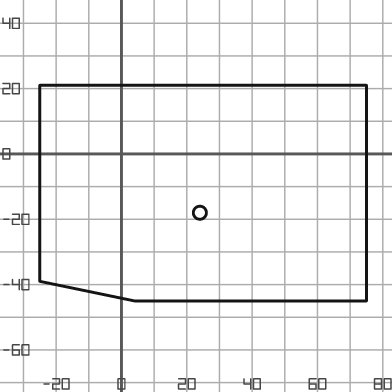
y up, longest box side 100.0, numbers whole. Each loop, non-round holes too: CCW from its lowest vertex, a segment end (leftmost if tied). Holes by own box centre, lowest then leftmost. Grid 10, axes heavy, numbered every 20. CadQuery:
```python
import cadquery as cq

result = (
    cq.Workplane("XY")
    .moveTo(4.0, -45.0)
    .lineTo(75.0, -45.0)
    .lineTo(75.0, 21.0)
    .lineTo(-25.0, 21.0)
    .lineTo(-25.0, -39.0)
    .close()
    .moveTo(24.0, -18.0)
    .circle(2.0)
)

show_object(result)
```